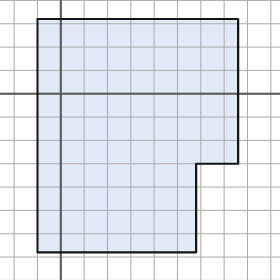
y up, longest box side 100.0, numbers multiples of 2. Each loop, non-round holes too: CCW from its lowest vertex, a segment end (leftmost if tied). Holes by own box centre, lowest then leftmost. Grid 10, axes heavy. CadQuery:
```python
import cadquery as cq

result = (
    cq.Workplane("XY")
    .moveTo(-10.0, -68.0)
    .lineTo(58.0, -68.0)
    .lineTo(58.0, -30.0)
    .lineTo(76.0, -30.0)
    .lineTo(76.0, 32.0)
    .lineTo(-10.0, 32.0)
    .close()
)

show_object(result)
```